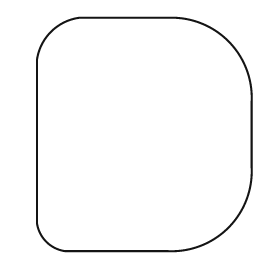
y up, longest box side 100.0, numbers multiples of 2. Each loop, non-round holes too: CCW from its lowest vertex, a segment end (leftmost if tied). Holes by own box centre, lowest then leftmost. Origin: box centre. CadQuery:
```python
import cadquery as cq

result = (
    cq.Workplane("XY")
    .moveTo(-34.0, -50.0)
    .lineTo(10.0, -50.0)
    .threePointArc((36.0, -40.0), (46.0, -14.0))
    .lineTo(46.0, 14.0)
    .threePointArc((36.0, 40.0), (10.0, 50.0))
    .lineTo(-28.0, 50.0)
    .threePointArc((-40.0, 44.0), (-46.0, 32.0))
    .lineTo(-46.0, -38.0)
    .threePointArc((-42.0, -46.0), (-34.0, -50.0))
    .close()
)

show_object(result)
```